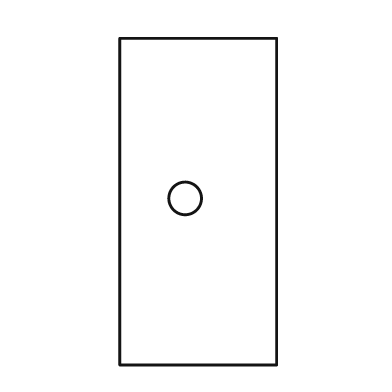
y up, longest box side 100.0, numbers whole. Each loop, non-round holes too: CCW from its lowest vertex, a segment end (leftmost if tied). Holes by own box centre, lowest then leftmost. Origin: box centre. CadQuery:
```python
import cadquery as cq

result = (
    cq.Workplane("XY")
    .moveTo(-24.0, -50.0)
    .lineTo(24.0, -50.0)
    .lineTo(24.0, 50.0)
    .lineTo(-24.0, 50.0)
    .close()
    .moveTo(-4.0, 1.0)
    .circle(5.0)
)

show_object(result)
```